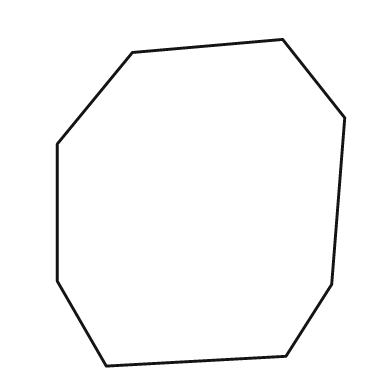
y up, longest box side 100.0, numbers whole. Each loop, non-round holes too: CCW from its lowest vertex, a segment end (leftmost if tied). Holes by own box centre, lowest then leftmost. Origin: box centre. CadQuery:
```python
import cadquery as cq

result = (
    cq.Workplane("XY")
    .moveTo(-29.0, -50.0)
    .lineTo(26.0, -47.0)
    .lineTo(40.0, -25.0)
    .lineTo(44.0, 26.0)
    .lineTo(25.0, 50.0)
    .lineTo(-21.0, 46.0)
    .lineTo(-44.0, 18.0)
    .lineTo(-44.0, -24.0)
    .close()
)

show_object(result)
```